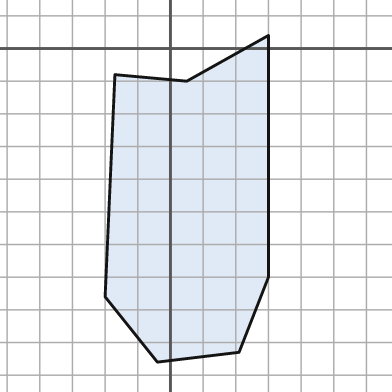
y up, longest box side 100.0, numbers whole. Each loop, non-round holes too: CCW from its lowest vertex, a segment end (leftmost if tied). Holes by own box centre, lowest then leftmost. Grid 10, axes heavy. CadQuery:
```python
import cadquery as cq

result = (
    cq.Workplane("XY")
    .moveTo(-4.0, -96.0)
    .lineTo(21.0, -93.0)
    .lineTo(30.0, -70.0)
    .lineTo(30.0, 4.0)
    .lineTo(5.0, -10.0)
    .lineTo(-17.0, -8.0)
    .lineTo(-20.0, -76.0)
    .close()
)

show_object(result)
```